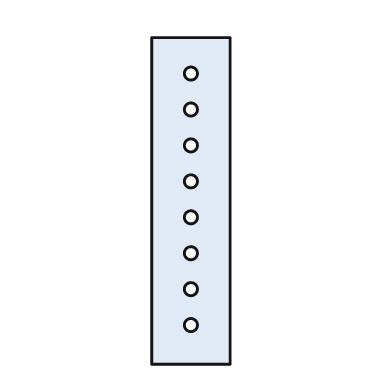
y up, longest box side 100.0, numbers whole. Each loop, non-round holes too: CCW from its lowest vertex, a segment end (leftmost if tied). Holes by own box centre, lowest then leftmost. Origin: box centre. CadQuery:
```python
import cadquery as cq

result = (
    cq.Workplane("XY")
    .moveTo(-12.0, -50.0)
    .lineTo(12.0, -50.0)
    .lineTo(12.0, 50.0)
    .lineTo(-12.0, 50.0)
    .close()
    .moveTo(0.0, -38.0)
    .circle(2.0)
    .moveTo(0.0, -27.0)
    .circle(2.0)
    .moveTo(0.0, -16.0)
    .circle(2.0)
    .moveTo(0.0, -5.0)
    .circle(2.0)
    .moveTo(0.0, 6.0)
    .circle(2.0)
    .moveTo(0.0, 17.0)
    .circle(2.0)
    .moveTo(0.0, 28.0)
    .circle(2.0)
    .moveTo(0.0, 39.0)
    .circle(2.0)
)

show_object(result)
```